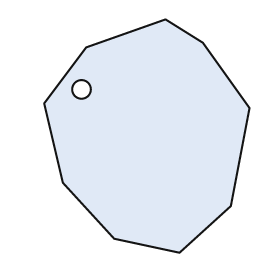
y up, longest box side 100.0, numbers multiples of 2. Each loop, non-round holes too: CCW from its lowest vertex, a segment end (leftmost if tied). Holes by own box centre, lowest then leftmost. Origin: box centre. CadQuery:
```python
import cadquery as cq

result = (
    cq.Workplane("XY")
    .moveTo(14.0, -50.0)
    .lineTo(36.0, -30.0)
    .lineTo(44.0, 12.0)
    .lineTo(24.0, 40.0)
    .lineTo(8.0, 50.0)
    .lineTo(-26.0, 38.0)
    .lineTo(-44.0, 14.0)
    .lineTo(-36.0, -20.0)
    .lineTo(-14.0, -44.0)
    .close()
    .moveTo(-28.0, 20.0)
    .circle(4.0)
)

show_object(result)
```